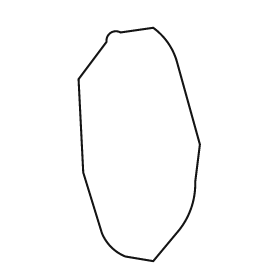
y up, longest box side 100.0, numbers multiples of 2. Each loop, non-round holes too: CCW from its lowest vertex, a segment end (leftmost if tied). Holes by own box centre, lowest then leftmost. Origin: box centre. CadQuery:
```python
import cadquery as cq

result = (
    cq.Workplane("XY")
    .moveTo(6.0, -50.0)
    .lineTo(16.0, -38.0)
    .threePointArc((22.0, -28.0), (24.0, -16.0))
    .lineTo(26.0, 0.0)
    .lineTo(16.0, 36.0)
    .threePointArc((12.0, 44.0), (6.0, 50.0))
    .lineTo(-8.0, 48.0)
    .threePointArc((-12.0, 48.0), (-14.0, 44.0))
    .lineTo(-26.0, 28.0)
    .lineTo(-24.0, -12.0)
    .lineTo(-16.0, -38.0)
    .threePointArc((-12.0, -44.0), (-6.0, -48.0))
    .close()
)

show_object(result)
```